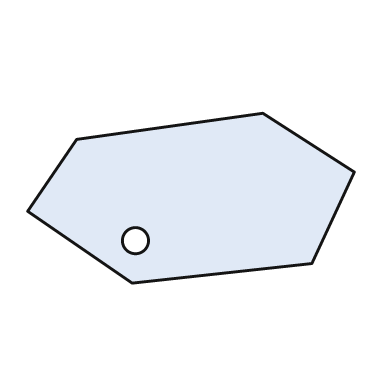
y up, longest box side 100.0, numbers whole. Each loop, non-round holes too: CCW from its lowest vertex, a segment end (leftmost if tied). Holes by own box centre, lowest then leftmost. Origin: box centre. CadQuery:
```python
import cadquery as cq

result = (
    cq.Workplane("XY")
    .moveTo(-18.0, -26.0)
    .lineTo(37.0, -20.0)
    .lineTo(50.0, 8.0)
    .lineTo(22.0, 26.0)
    .lineTo(-35.0, 18.0)
    .lineTo(-50.0, -4.0)
    .close()
    .moveTo(-17.0, -13.0)
    .circle(4.0)
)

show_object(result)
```